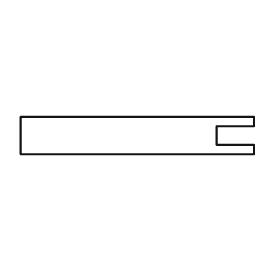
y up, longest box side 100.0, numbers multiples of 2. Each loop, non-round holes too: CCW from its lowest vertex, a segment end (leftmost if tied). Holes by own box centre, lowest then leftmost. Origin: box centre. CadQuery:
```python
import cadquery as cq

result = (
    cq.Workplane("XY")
    .moveTo(-50.0, -8.0)
    .lineTo(50.0, -8.0)
    .lineTo(50.0, -4.0)
    .lineTo(34.0, -4.0)
    .lineTo(34.0, 4.0)
    .lineTo(50.0, 4.0)
    .lineTo(50.0, 8.0)
    .lineTo(-50.0, 8.0)
    .close()
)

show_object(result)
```